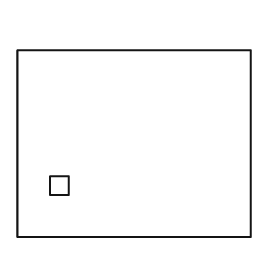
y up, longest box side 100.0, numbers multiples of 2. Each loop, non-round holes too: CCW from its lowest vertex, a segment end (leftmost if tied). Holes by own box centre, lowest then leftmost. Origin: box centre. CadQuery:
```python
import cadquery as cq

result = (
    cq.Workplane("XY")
    .moveTo(-50.0, -40.0)
    .lineTo(50.0, -40.0)
    .lineTo(50.0, 40.0)
    .lineTo(-50.0, 40.0)
    .close()
    .moveTo(-36.0, -22.0)
    .lineTo(-28.0, -22.0)
    .lineTo(-28.0, -14.0)
    .lineTo(-36.0, -14.0)
    .close()
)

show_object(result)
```